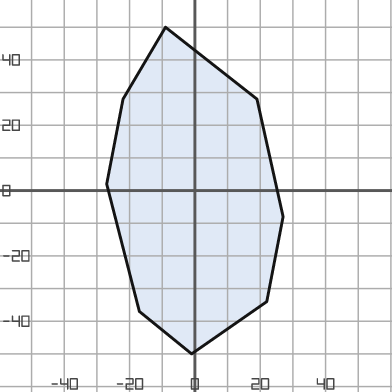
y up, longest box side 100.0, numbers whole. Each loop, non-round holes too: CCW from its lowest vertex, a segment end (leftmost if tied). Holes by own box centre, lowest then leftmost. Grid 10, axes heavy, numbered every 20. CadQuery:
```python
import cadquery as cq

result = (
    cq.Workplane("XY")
    .moveTo(-1.0, -50.0)
    .lineTo(22.0, -34.0)
    .lineTo(27.0, -8.0)
    .lineTo(19.0, 28.0)
    .lineTo(-9.0, 50.0)
    .lineTo(-22.0, 28.0)
    .lineTo(-27.0, 2.0)
    .lineTo(-17.0, -37.0)
    .close()
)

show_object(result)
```